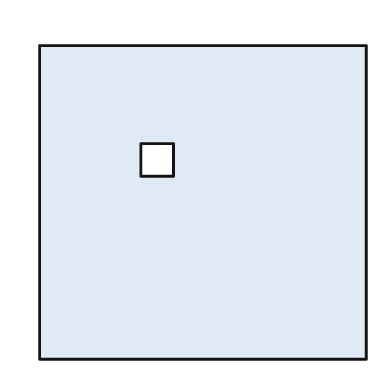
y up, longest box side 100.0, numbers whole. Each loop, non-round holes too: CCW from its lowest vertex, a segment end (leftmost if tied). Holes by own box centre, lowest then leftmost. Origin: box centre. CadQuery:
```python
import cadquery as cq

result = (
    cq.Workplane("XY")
    .moveTo(-50.0, -48.0)
    .lineTo(50.0, -48.0)
    .lineTo(50.0, 48.0)
    .lineTo(-50.0, 48.0)
    .close()
    .moveTo(-19.0, 8.0)
    .lineTo(-9.0, 8.0)
    .lineTo(-9.0, 18.0)
    .lineTo(-19.0, 18.0)
    .close()
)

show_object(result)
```